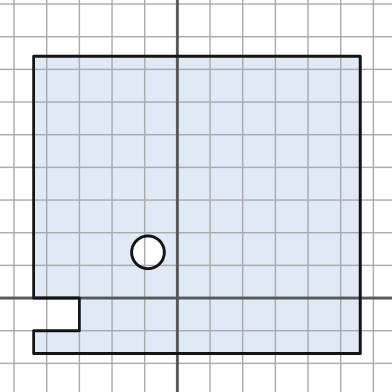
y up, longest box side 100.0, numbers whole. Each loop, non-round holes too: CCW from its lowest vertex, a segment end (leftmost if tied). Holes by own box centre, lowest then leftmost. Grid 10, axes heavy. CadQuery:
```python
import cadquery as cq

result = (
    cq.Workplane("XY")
    .moveTo(-44.0, -17.0)
    .lineTo(56.0, -17.0)
    .lineTo(56.0, 74.0)
    .lineTo(-44.0, 74.0)
    .lineTo(-44.0, 0.0)
    .lineTo(-30.0, 0.0)
    .lineTo(-30.0, -10.0)
    .lineTo(-44.0, -10.0)
    .close()
    .moveTo(-9.0, 14.0)
    .circle(5.0)
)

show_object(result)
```